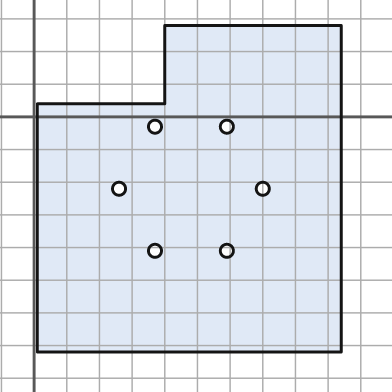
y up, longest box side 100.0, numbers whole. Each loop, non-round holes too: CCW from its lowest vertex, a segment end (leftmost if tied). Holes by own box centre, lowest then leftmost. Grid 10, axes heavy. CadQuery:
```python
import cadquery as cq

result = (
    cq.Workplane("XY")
    .moveTo(1.0, -72.0)
    .lineTo(94.0, -72.0)
    .lineTo(94.0, 28.0)
    .lineTo(40.0, 28.0)
    .lineTo(40.0, 4.0)
    .lineTo(1.0, 4.0)
    .close()
    .moveTo(37.0, -41.0)
    .circle(2.0)
    .moveTo(59.0, -41.0)
    .circle(2.0)
    .moveTo(26.0, -22.0)
    .circle(2.0)
    .moveTo(70.0, -22.0)
    .circle(2.0)
    .moveTo(37.0, -3.0)
    .circle(2.0)
    .moveTo(59.0, -3.0)
    .circle(2.0)
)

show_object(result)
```